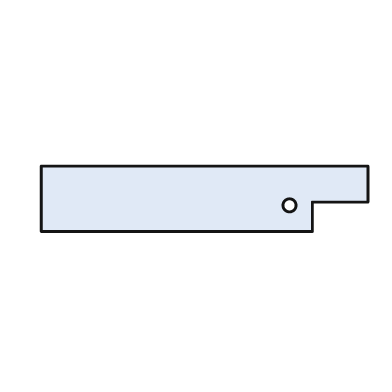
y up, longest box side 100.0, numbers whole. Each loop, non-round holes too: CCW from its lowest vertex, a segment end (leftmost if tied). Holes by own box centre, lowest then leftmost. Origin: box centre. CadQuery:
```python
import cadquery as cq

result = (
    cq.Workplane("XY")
    .moveTo(-50.0, -10.0)
    .lineTo(33.0, -10.0)
    .lineTo(33.0, -1.0)
    .lineTo(50.0, -1.0)
    .lineTo(50.0, 10.0)
    .lineTo(-50.0, 10.0)
    .close()
    .moveTo(26.0, -2.0)
    .circle(2.0)
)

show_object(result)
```